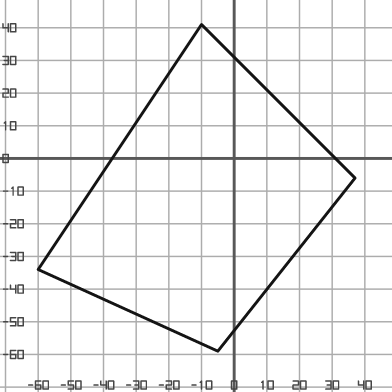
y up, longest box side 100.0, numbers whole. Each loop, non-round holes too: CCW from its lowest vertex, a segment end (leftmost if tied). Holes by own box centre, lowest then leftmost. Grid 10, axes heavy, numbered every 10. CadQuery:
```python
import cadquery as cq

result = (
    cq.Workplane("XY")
    .moveTo(-5.0, -59.0)
    .lineTo(37.0, -6.0)
    .lineTo(-10.0, 41.0)
    .lineTo(-60.0, -34.0)
    .close()
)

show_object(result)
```